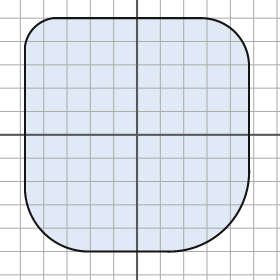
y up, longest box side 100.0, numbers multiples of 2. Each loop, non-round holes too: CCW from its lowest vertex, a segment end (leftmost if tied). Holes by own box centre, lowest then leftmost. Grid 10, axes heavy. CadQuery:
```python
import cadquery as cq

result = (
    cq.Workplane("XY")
    .moveTo(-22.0, -50.0)
    .lineTo(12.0, -50.0)
    .threePointArc((38.0, -40.0), (48.0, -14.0))
    .lineTo(48.0, 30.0)
    .threePointArc((42.0, 44.0), (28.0, 50.0))
    .lineTo(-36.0, 50.0)
    .threePointArc((-44.0, 46.0), (-48.0, 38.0))
    .lineTo(-48.0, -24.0)
    .threePointArc((-40.0, -42.0), (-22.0, -50.0))
    .close()
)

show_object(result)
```